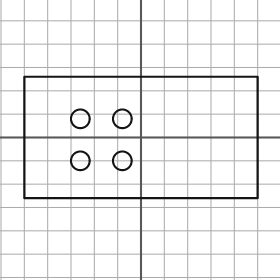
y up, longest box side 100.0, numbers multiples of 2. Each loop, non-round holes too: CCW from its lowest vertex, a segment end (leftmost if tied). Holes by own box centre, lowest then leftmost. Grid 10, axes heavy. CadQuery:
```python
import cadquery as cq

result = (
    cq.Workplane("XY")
    .moveTo(-50.0, -26.0)
    .lineTo(50.0, -26.0)
    .lineTo(50.0, 26.0)
    .lineTo(-50.0, 26.0)
    .close()
    .moveTo(-26.0, -10.0)
    .circle(4.0)
    .moveTo(-8.0, -10.0)
    .circle(4.0)
    .moveTo(-26.0, 8.0)
    .circle(4.0)
    .moveTo(-8.0, 8.0)
    .circle(4.0)
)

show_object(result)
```